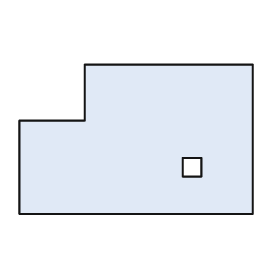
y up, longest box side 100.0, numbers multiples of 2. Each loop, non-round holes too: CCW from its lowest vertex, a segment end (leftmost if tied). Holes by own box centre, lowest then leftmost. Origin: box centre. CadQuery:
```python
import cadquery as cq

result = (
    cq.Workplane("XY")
    .moveTo(-50.0, -32.0)
    .lineTo(50.0, -32.0)
    .lineTo(50.0, 32.0)
    .lineTo(-22.0, 32.0)
    .lineTo(-22.0, 8.0)
    .lineTo(-50.0, 8.0)
    .close()
    .moveTo(20.0, -16.0)
    .lineTo(28.0, -16.0)
    .lineTo(28.0, -8.0)
    .lineTo(20.0, -8.0)
    .close()
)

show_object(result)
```